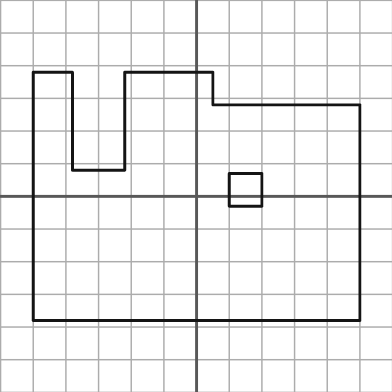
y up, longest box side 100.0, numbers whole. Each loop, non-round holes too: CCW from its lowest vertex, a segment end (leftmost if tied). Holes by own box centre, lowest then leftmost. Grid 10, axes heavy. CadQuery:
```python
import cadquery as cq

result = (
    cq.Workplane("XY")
    .moveTo(-50.0, -38.0)
    .lineTo(50.0, -38.0)
    .lineTo(50.0, 28.0)
    .lineTo(5.0, 28.0)
    .lineTo(5.0, 38.0)
    .lineTo(-22.0, 38.0)
    .lineTo(-22.0, 8.0)
    .lineTo(-38.0, 8.0)
    .lineTo(-38.0, 38.0)
    .lineTo(-50.0, 38.0)
    .close()
    .moveTo(10.0, -3.0)
    .lineTo(20.0, -3.0)
    .lineTo(20.0, 7.0)
    .lineTo(10.0, 7.0)
    .close()
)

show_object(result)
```